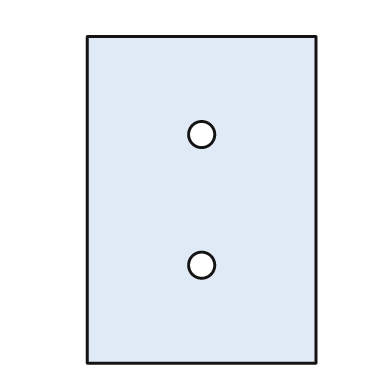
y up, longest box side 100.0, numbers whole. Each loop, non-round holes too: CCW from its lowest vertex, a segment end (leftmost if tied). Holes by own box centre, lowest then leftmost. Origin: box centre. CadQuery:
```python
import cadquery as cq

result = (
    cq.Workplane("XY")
    .moveTo(-35.0, -50.0)
    .lineTo(35.0, -50.0)
    .lineTo(35.0, 50.0)
    .lineTo(-35.0, 50.0)
    .close()
    .moveTo(0.0, -20.0)
    .circle(4.0)
    .moveTo(0.0, 20.0)
    .circle(4.0)
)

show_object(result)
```